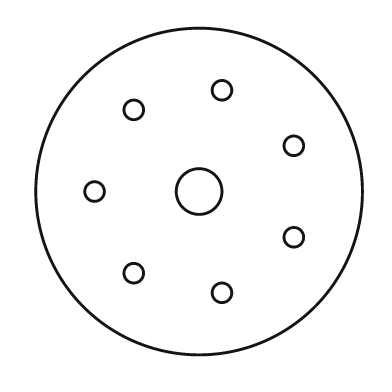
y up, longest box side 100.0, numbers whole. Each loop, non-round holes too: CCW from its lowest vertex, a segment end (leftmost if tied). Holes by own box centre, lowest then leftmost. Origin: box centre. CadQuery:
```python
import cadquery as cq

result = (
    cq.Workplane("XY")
    .moveTo(0.0, 0.0)
    .circle(50.0)
    .moveTo(7.0, -31.0)
    .circle(3.0)
    .moveTo(-20.0, -25.0)
    .circle(3.0)
    .moveTo(29.0, -14.0)
    .circle(3.0)
    .moveTo(-32.0, 0.0)
    .circle(3.0)
    .moveTo(0.0, 0.0)
    .circle(7.0)
    .moveTo(29.0, 14.0)
    .circle(3.0)
    .moveTo(-20.0, 25.0)
    .circle(3.0)
    .moveTo(7.0, 31.0)
    .circle(3.0)
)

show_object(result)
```